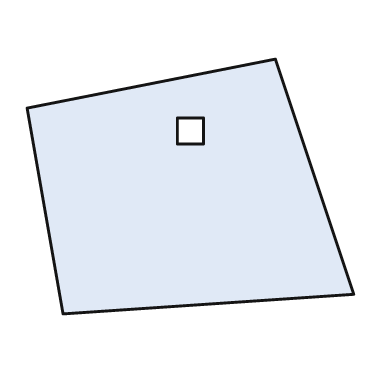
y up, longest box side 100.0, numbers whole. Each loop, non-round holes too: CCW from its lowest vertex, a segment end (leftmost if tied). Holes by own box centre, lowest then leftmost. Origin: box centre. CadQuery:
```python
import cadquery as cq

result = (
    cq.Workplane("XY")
    .moveTo(-39.0, -39.0)
    .lineTo(50.0, -33.0)
    .lineTo(26.0, 39.0)
    .lineTo(-50.0, 24.0)
    .close()
    .moveTo(-4.0, 13.0)
    .lineTo(4.0, 13.0)
    .lineTo(4.0, 21.0)
    .lineTo(-4.0, 21.0)
    .close()
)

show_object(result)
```